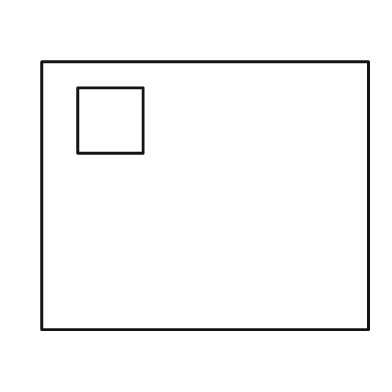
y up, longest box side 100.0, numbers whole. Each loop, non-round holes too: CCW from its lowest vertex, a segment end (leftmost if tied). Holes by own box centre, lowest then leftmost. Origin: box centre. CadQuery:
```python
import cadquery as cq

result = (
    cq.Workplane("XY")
    .moveTo(-50.0, -41.0)
    .lineTo(50.0, -41.0)
    .lineTo(50.0, 41.0)
    .lineTo(-50.0, 41.0)
    .close()
    .moveTo(-39.0, 13.0)
    .lineTo(-19.0, 13.0)
    .lineTo(-19.0, 33.0)
    .lineTo(-39.0, 33.0)
    .close()
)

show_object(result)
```